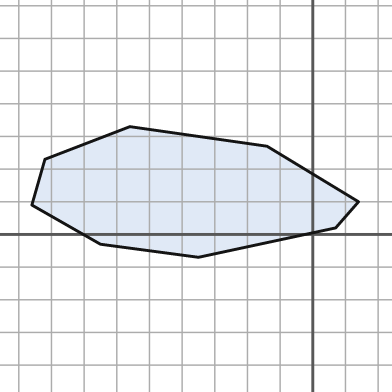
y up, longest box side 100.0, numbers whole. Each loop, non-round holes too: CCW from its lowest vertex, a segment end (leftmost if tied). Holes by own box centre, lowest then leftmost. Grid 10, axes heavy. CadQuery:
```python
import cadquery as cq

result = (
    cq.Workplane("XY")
    .moveTo(-35.0, -7.0)
    .lineTo(7.0, 2.0)
    .lineTo(14.0, 10.0)
    .lineTo(-14.0, 27.0)
    .lineTo(-56.0, 33.0)
    .lineTo(-82.0, 23.0)
    .lineTo(-86.0, 9.0)
    .lineTo(-65.0, -3.0)
    .close()
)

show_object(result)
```